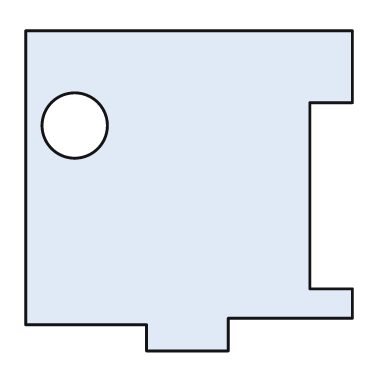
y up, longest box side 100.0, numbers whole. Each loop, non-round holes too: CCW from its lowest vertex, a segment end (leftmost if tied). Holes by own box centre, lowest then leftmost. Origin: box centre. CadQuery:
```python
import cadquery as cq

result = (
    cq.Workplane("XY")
    .moveTo(-13.0, -49.0)
    .lineTo(12.0, -49.0)
    .lineTo(12.0, -39.0)
    .lineTo(50.0, -39.0)
    .lineTo(50.0, -30.0)
    .lineTo(37.0, -30.0)
    .lineTo(37.0, 27.0)
    .lineTo(50.0, 27.0)
    .lineTo(50.0, 49.0)
    .lineTo(-50.0, 49.0)
    .lineTo(-50.0, -41.0)
    .lineTo(-13.0, -41.0)
    .close()
    .moveTo(-35.0, 20.0)
    .circle(10.0)
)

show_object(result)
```